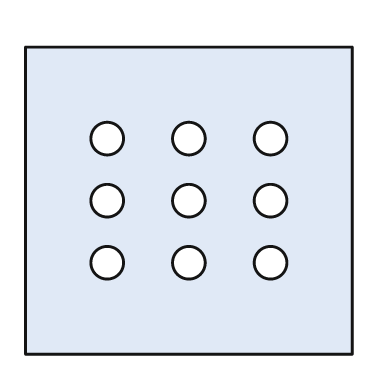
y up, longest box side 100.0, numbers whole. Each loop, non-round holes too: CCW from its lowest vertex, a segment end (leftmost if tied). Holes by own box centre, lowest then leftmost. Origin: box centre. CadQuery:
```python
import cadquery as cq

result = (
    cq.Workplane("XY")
    .moveTo(-50.0, -47.0)
    .lineTo(50.0, -47.0)
    .lineTo(50.0, 47.0)
    .lineTo(-50.0, 47.0)
    .close()
    .moveTo(-25.0, -19.0)
    .circle(5.0)
    .moveTo(0.0, -19.0)
    .circle(5.0)
    .moveTo(25.0, -19.0)
    .circle(5.0)
    .moveTo(-25.0, 0.0)
    .circle(5.0)
    .moveTo(0.0, 0.0)
    .circle(5.0)
    .moveTo(25.0, 0.0)
    .circle(5.0)
    .moveTo(-25.0, 19.0)
    .circle(5.0)
    .moveTo(0.0, 19.0)
    .circle(5.0)
    .moveTo(25.0, 19.0)
    .circle(5.0)
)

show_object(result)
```